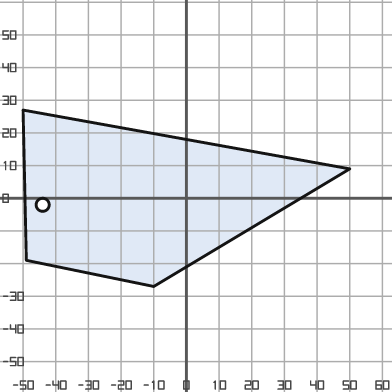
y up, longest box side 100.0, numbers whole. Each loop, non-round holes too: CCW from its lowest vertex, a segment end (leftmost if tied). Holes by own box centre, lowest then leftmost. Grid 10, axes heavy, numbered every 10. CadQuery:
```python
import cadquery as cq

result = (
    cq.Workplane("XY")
    .moveTo(-10.0, -27.0)
    .lineTo(50.0, 9.0)
    .lineTo(-50.0, 27.0)
    .lineTo(-49.0, -19.0)
    .close()
    .moveTo(-44.0, -2.0)
    .circle(2.0)
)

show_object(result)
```